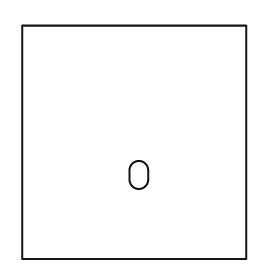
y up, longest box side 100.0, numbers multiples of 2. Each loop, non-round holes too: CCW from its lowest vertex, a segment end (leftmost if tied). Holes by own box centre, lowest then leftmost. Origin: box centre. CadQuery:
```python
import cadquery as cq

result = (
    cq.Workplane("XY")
    .moveTo(-48.0, -50.0)
    .lineTo(48.0, -50.0)
    .lineTo(48.0, 50.0)
    .lineTo(-48.0, 50.0)
    .close()
    .moveTo(-2.0, -16.0)
    .threePointArc((2.0, -20.0), (6.0, -16.0))
    .lineTo(6.0, -12.0)
    .threePointArc((2.0, -8.0), (-2.0, -12.0))
    .close()
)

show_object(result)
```